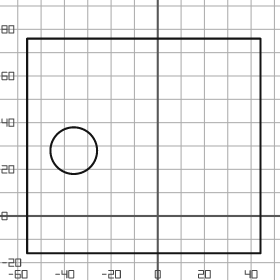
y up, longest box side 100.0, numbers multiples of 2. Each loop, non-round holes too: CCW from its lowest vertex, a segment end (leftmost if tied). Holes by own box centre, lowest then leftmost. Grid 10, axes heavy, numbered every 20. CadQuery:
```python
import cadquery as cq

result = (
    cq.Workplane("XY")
    .moveTo(-56.0, -16.0)
    .lineTo(44.0, -16.0)
    .lineTo(44.0, 76.0)
    .lineTo(-56.0, 76.0)
    .close()
    .moveTo(-36.0, 28.0)
    .circle(10.0)
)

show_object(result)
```